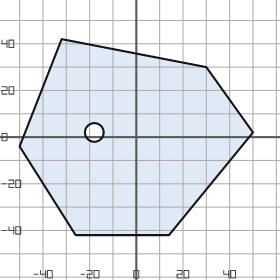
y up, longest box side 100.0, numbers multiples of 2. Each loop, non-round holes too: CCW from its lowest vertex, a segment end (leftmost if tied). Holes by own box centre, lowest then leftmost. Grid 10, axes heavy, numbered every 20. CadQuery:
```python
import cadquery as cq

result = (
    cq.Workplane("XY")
    .moveTo(-26.0, -42.0)
    .lineTo(14.0, -42.0)
    .lineTo(50.0, 2.0)
    .lineTo(30.0, 30.0)
    .lineTo(-32.0, 42.0)
    .lineTo(-50.0, -4.0)
    .close()
    .moveTo(-18.0, 2.0)
    .circle(4.0)
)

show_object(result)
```